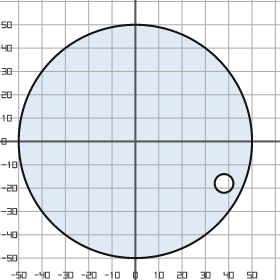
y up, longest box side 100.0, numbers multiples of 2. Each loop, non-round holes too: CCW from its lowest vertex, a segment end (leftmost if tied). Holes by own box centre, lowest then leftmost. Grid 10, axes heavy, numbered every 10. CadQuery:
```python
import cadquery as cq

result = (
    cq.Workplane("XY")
    .moveTo(0.0, 0.0)
    .circle(50.0)
    .moveTo(38.0, -18.0)
    .circle(4.0)
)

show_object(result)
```